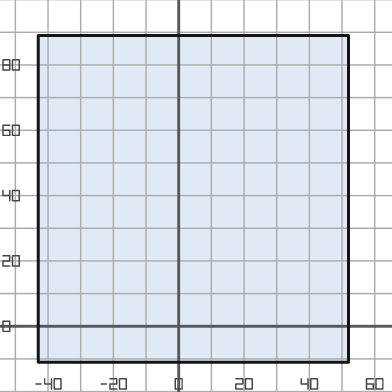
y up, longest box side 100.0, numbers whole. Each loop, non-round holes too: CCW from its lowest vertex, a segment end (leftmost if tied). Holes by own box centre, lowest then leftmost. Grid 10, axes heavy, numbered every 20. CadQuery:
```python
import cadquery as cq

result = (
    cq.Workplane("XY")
    .moveTo(-43.0, -11.0)
    .lineTo(52.0, -11.0)
    .lineTo(52.0, 89.0)
    .lineTo(-43.0, 89.0)
    .close()
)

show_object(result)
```